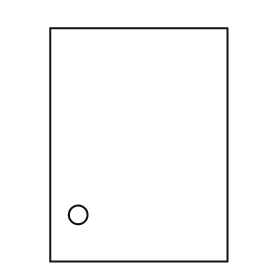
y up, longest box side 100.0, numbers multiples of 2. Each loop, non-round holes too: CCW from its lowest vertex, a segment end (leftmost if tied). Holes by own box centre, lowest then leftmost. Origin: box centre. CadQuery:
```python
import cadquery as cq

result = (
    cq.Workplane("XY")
    .moveTo(-38.0, -50.0)
    .lineTo(38.0, -50.0)
    .lineTo(38.0, 50.0)
    .lineTo(-38.0, 50.0)
    .close()
    .moveTo(-26.0, -30.0)
    .circle(4.0)
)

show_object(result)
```